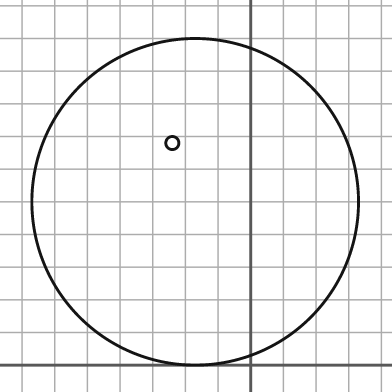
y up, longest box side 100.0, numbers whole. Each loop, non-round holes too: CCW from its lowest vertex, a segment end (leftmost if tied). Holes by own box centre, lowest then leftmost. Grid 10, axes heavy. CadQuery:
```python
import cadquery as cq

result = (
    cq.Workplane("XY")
    .moveTo(-17.0, 50.0)
    .circle(50.0)
    .moveTo(-24.0, 68.0)
    .circle(2.0)
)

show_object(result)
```